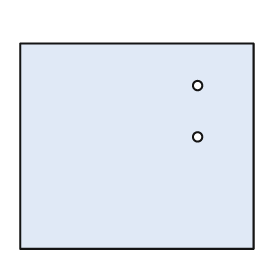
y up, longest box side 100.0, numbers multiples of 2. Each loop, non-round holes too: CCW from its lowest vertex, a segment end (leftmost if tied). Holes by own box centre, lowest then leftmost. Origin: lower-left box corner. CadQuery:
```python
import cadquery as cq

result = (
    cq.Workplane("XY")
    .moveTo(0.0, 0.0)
    .lineTo(100.0, 0.0)
    .lineTo(100.0, 88.0)
    .lineTo(0.0, 88.0)
    .close()
    .moveTo(76.0, 48.0)
    .circle(2.0)
    .moveTo(76.0, 70.0)
    .circle(2.0)
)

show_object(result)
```